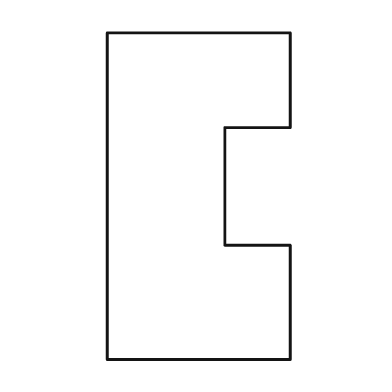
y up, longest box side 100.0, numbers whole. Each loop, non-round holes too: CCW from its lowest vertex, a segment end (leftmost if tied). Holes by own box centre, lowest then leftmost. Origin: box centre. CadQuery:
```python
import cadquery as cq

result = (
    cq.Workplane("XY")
    .moveTo(-28.0, -50.0)
    .lineTo(28.0, -50.0)
    .lineTo(28.0, -15.0)
    .lineTo(8.0, -15.0)
    .lineTo(8.0, 21.0)
    .lineTo(28.0, 21.0)
    .lineTo(28.0, 50.0)
    .lineTo(-28.0, 50.0)
    .close()
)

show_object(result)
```